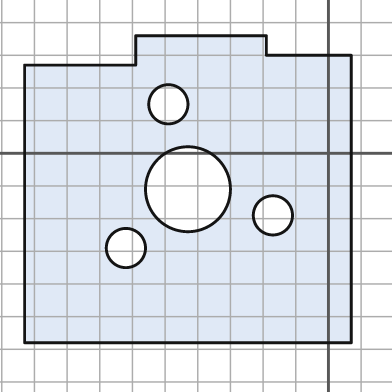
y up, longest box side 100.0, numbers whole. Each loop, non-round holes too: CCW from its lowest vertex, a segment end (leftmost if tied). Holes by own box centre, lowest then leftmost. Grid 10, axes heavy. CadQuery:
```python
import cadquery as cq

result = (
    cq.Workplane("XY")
    .moveTo(-93.0, -58.0)
    .lineTo(7.0, -58.0)
    .lineTo(7.0, 30.0)
    .lineTo(-19.0, 30.0)
    .lineTo(-19.0, 36.0)
    .lineTo(-59.0, 36.0)
    .lineTo(-59.0, 27.0)
    .lineTo(-93.0, 27.0)
    .close()
    .moveTo(-62.0, -29.0)
    .circle(6.0)
    .moveTo(-17.0, -19.0)
    .circle(6.0)
    .moveTo(-43.0, -11.0)
    .circle(13.0)
    .moveTo(-49.0, 15.0)
    .circle(6.0)
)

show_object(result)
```